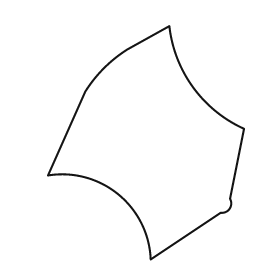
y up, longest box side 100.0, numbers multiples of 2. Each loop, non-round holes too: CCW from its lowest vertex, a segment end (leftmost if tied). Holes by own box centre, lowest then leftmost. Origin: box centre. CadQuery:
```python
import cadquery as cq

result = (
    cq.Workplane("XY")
    .moveTo(2.0, -50.0)
    .lineTo(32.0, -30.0)
    .threePointArc((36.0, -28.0), (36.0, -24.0))
    .lineTo(42.0, 6.0)
    .threePointArc((20.0, 24.0), (10.0, 50.0))
    .lineTo(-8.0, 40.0)
    .threePointArc((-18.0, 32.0), (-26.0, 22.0))
    .lineTo(-42.0, -14.0)
    .threePointArc((-12.0, -22.0), (2.0, -50.0))
    .close()
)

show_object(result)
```